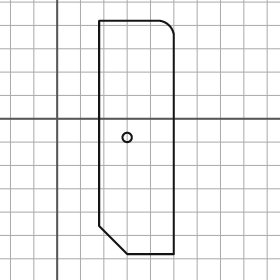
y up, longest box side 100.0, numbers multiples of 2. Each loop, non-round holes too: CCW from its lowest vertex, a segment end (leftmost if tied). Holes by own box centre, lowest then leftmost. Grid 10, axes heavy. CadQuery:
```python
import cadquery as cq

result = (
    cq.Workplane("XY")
    .moveTo(30.0, -58.0)
    .lineTo(50.0, -58.0)
    .lineTo(50.0, 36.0)
    .threePointArc((48.0, 40.0), (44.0, 42.0))
    .lineTo(18.0, 42.0)
    .lineTo(18.0, -46.0)
    .close()
    .moveTo(30.0, -8.0)
    .circle(2.0)
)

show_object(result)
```